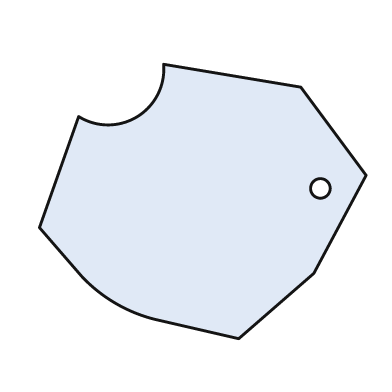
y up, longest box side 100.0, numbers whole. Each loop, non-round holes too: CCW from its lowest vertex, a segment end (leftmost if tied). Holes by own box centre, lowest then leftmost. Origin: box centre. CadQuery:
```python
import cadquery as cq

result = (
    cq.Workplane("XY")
    .moveTo(11.0, -42.0)
    .lineTo(34.0, -22.0)
    .lineTo(50.0, 8.0)
    .lineTo(30.0, 35.0)
    .lineTo(-12.0, 42.0)
    .threePointArc((-20.0, 26.0), (-38.0, 26.0))
    .lineTo(-50.0, -8.0)
    .lineTo(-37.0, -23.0)
    .threePointArc((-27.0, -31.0), (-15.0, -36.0))
    .close()
    .moveTo(36.0, 4.0)
    .circle(3.0)
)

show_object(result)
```